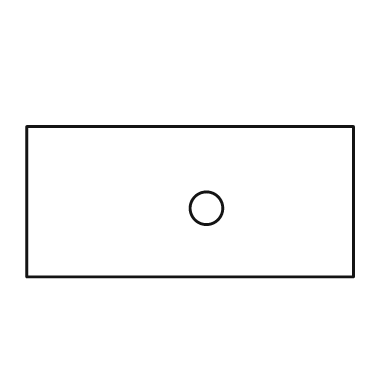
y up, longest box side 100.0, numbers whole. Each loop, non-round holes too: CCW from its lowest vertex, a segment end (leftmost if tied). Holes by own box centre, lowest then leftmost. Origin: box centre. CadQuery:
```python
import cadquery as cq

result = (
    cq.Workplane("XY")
    .moveTo(-50.0, -23.0)
    .lineTo(50.0, -23.0)
    .lineTo(50.0, 23.0)
    .lineTo(-50.0, 23.0)
    .close()
    .moveTo(5.0, -2.0)
    .circle(5.0)
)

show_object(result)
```